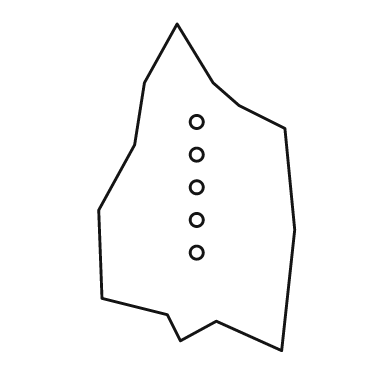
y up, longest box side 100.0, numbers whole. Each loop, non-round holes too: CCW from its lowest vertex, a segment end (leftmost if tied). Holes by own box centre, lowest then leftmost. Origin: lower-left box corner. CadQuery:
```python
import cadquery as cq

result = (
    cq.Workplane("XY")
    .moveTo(56.0, 0.0)
    .lineTo(60.0, 37.0)
    .lineTo(57.0, 68.0)
    .lineTo(43.0, 75.0)
    .lineTo(35.0, 82.0)
    .lineTo(24.0, 100.0)
    .lineTo(14.0, 82.0)
    .lineTo(11.0, 63.0)
    .lineTo(0.0, 43.0)
    .lineTo(1.0, 16.0)
    .lineTo(21.0, 11.0)
    .lineTo(25.0, 3.0)
    .lineTo(36.0, 9.0)
    .close()
    .moveTo(30.0, 30.0)
    .circle(2.0)
    .moveTo(30.0, 40.0)
    .circle(2.0)
    .moveTo(30.0, 50.0)
    .circle(2.0)
    .moveTo(30.0, 60.0)
    .circle(2.0)
    .moveTo(30.0, 70.0)
    .circle(2.0)
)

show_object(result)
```